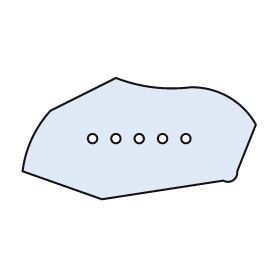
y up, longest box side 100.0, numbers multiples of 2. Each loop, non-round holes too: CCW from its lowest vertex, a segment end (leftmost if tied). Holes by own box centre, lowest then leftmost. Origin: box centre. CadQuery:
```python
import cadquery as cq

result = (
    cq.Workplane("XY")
    .moveTo(-16.0, -26.0)
    .lineTo(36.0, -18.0)
    .threePointArc((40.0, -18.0), (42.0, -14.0))
    .lineTo(50.0, 6.0)
    .threePointArc((38.0, 18.0), (22.0, 22.0))
    .threePointArc((6.0, 22.0), (-10.0, 26.0))
    .lineTo(-38.0, 12.0)
    .threePointArc((-46.0, 0.0), (-50.0, -14.0))
    .close()
    .moveTo(-20.0, 0.0)
    .circle(2.0)
    .moveTo(-10.0, 0.0)
    .circle(2.0)
    .moveTo(0.0, 0.0)
    .circle(2.0)
    .moveTo(10.0, 0.0)
    .circle(2.0)
    .moveTo(20.0, 0.0)
    .circle(2.0)
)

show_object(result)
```